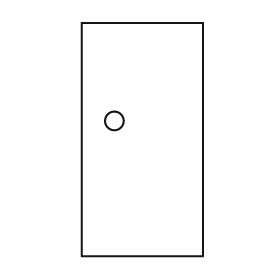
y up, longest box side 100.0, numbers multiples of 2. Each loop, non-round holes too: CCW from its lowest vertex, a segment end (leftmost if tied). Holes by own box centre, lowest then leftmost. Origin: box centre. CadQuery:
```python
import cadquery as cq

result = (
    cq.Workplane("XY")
    .moveTo(-26.0, -50.0)
    .lineTo(26.0, -50.0)
    .lineTo(26.0, 50.0)
    .lineTo(-26.0, 50.0)
    .close()
    .moveTo(-12.0, 8.0)
    .circle(4.0)
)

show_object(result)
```